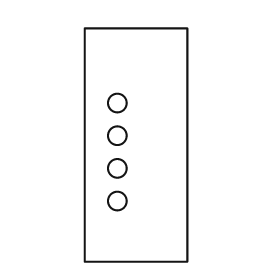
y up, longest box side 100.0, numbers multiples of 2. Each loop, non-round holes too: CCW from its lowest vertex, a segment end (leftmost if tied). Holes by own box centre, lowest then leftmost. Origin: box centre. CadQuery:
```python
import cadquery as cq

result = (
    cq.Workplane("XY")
    .moveTo(-22.0, -50.0)
    .lineTo(22.0, -50.0)
    .lineTo(22.0, 50.0)
    .lineTo(-22.0, 50.0)
    .close()
    .moveTo(-8.0, -24.0)
    .circle(4.0)
    .moveTo(-8.0, -10.0)
    .circle(4.0)
    .moveTo(-8.0, 4.0)
    .circle(4.0)
    .moveTo(-8.0, 18.0)
    .circle(4.0)
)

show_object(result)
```